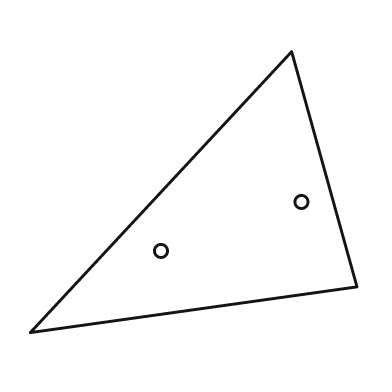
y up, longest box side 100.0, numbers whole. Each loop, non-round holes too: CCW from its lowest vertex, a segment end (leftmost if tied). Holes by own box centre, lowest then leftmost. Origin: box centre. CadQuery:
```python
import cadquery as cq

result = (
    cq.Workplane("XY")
    .moveTo(-50.0, -43.0)
    .lineTo(50.0, -29.0)
    .lineTo(30.0, 43.0)
    .close()
    .moveTo(-10.0, -18.0)
    .circle(2.0)
    .moveTo(33.0, -3.0)
    .circle(2.0)
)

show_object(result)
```